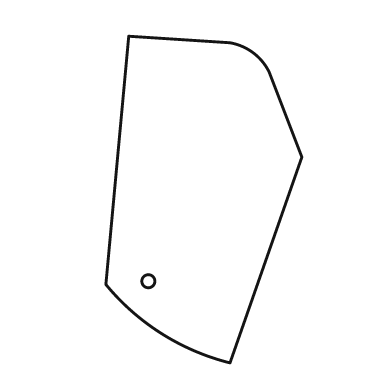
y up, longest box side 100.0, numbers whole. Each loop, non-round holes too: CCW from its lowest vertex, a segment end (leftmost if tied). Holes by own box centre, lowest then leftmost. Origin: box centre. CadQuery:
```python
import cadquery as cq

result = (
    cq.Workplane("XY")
    .moveTo(8.0, -50.0)
    .lineTo(30.0, 13.0)
    .lineTo(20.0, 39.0)
    .threePointArc((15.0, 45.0), (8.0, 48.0))
    .lineTo(-23.0, 50.0)
    .lineTo(-30.0, -26.0)
    .threePointArc((-13.0, -41.0), (8.0, -50.0))
    .close()
    .moveTo(-17.0, -25.0)
    .circle(2.0)
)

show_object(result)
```